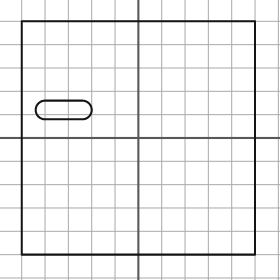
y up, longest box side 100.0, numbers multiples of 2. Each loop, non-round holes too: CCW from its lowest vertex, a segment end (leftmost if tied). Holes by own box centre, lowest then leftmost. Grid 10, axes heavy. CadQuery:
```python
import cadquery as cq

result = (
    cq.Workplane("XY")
    .moveTo(-50.0, -50.0)
    .lineTo(50.0, -50.0)
    .lineTo(50.0, 50.0)
    .lineTo(-50.0, 50.0)
    .close()
    .moveTo(-40.0, 8.0)
    .lineTo(-24.0, 8.0)
    .threePointArc((-20.0, 12.0), (-24.0, 16.0))
    .lineTo(-40.0, 16.0)
    .threePointArc((-44.0, 12.0), (-40.0, 8.0))
    .close()
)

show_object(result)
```